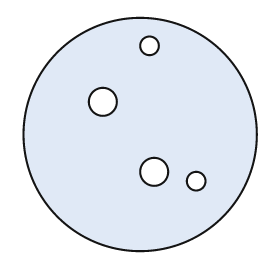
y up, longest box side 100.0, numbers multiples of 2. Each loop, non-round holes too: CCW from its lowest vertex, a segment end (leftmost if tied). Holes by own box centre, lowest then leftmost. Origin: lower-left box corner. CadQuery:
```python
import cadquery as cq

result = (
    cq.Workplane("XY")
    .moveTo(50.0, 50.0)
    .circle(50.0)
    .moveTo(74.0, 30.0)
    .circle(4.0)
    .moveTo(56.0, 34.0)
    .circle(6.0)
    .moveTo(34.0, 64.0)
    .circle(6.0)
    .moveTo(54.0, 88.0)
    .circle(4.0)
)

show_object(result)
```